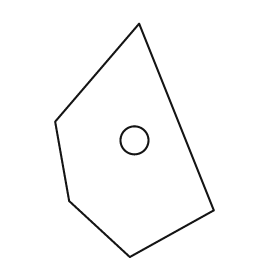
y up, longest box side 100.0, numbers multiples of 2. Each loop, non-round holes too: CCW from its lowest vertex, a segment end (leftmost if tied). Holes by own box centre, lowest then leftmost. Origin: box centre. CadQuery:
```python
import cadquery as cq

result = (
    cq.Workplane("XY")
    .moveTo(-2.0, -50.0)
    .lineTo(34.0, -30.0)
    .lineTo(2.0, 50.0)
    .lineTo(-34.0, 8.0)
    .lineTo(-28.0, -26.0)
    .close()
    .moveTo(0.0, 0.0)
    .circle(6.0)
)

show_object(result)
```